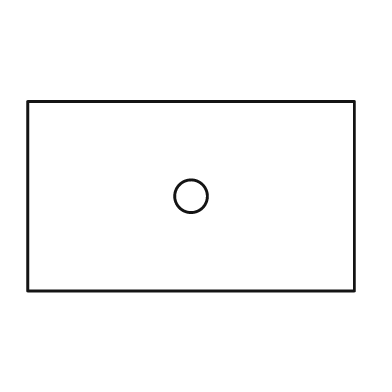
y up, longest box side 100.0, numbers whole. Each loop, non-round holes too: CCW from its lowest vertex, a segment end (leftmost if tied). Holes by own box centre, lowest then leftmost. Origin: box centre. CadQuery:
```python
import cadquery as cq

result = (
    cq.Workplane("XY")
    .moveTo(-50.0, -29.0)
    .lineTo(50.0, -29.0)
    .lineTo(50.0, 29.0)
    .lineTo(-50.0, 29.0)
    .close()
    .moveTo(0.0, 0.0)
    .circle(5.0)
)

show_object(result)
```